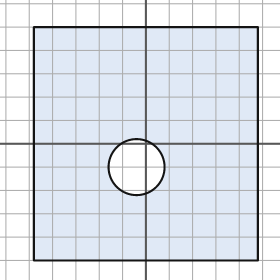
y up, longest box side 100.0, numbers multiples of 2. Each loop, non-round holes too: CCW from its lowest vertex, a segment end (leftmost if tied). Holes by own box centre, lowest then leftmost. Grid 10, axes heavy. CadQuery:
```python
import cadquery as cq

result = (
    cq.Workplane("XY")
    .moveTo(-48.0, -50.0)
    .lineTo(48.0, -50.0)
    .lineTo(48.0, 50.0)
    .lineTo(-48.0, 50.0)
    .close()
    .moveTo(-4.0, -10.0)
    .circle(12.0)
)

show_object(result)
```